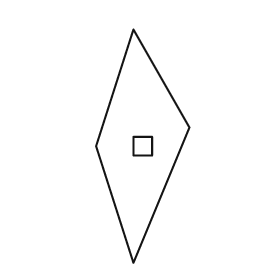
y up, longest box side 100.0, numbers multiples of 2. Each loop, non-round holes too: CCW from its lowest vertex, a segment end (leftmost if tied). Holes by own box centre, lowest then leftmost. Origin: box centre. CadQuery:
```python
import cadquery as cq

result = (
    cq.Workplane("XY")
    .moveTo(-4.0, -50.0)
    .lineTo(20.0, 8.0)
    .lineTo(-4.0, 50.0)
    .lineTo(-20.0, 0.0)
    .close()
    .moveTo(-4.0, -4.0)
    .lineTo(4.0, -4.0)
    .lineTo(4.0, 4.0)
    .lineTo(-4.0, 4.0)
    .close()
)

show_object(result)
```